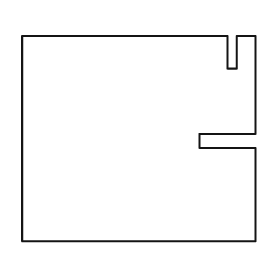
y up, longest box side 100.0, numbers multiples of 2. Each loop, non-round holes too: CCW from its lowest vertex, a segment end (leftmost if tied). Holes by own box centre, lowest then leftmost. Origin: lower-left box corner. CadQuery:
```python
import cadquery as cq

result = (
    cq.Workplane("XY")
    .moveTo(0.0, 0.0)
    .lineTo(100.0, 0.0)
    .lineTo(100.0, 40.0)
    .lineTo(76.0, 40.0)
    .lineTo(76.0, 46.0)
    .lineTo(100.0, 46.0)
    .lineTo(100.0, 88.0)
    .lineTo(92.0, 88.0)
    .lineTo(92.0, 74.0)
    .lineTo(88.0, 74.0)
    .lineTo(88.0, 88.0)
    .lineTo(0.0, 88.0)
    .close()
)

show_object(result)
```